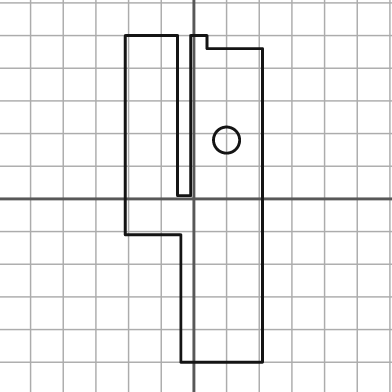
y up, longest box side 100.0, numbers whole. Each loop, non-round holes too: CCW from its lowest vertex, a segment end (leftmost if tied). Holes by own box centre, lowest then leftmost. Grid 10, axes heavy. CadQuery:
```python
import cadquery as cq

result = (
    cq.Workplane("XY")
    .moveTo(-4.0, -50.0)
    .lineTo(21.0, -50.0)
    .lineTo(21.0, 46.0)
    .lineTo(4.0, 46.0)
    .lineTo(4.0, 50.0)
    .lineTo(-1.0, 50.0)
    .lineTo(-1.0, 1.0)
    .lineTo(-5.0, 1.0)
    .lineTo(-5.0, 50.0)
    .lineTo(-21.0, 50.0)
    .lineTo(-21.0, -11.0)
    .lineTo(-4.0, -11.0)
    .close()
    .moveTo(10.0, 18.0)
    .circle(4.0)
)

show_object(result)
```